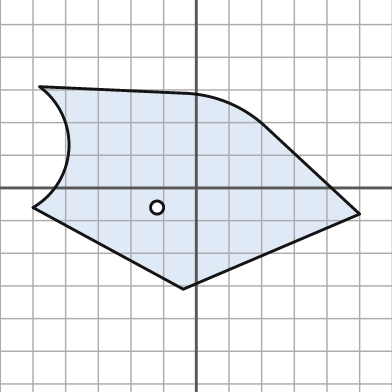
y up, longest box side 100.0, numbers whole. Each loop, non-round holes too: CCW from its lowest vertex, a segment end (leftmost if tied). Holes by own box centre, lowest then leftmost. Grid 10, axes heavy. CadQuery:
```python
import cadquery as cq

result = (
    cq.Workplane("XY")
    .moveTo(-4.0, -31.0)
    .lineTo(50.0, -8.0)
    .lineTo(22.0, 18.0)
    .threePointArc((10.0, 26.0), (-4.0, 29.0))
    .lineTo(-48.0, 31.0)
    .threePointArc((-39.0, 12.0), (-50.0, -6.0))
    .close()
    .moveTo(-12.0, -6.0)
    .circle(2.0)
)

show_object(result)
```